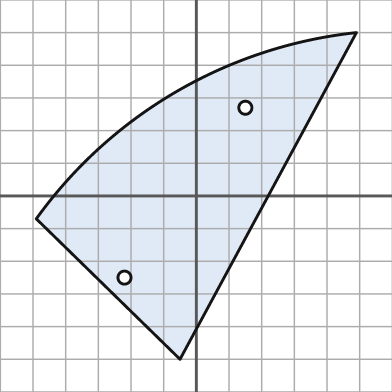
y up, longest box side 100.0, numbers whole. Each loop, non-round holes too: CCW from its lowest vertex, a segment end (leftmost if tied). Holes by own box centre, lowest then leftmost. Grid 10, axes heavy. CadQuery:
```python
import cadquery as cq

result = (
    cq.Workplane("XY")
    .moveTo(-5.0, -50.0)
    .lineTo(49.0, 50.0)
    .threePointArc((-6.0, 32.0), (-49.0, -7.0))
    .close()
    .moveTo(-22.0, -25.0)
    .circle(2.0)
    .moveTo(15.0, 27.0)
    .circle(2.0)
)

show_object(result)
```